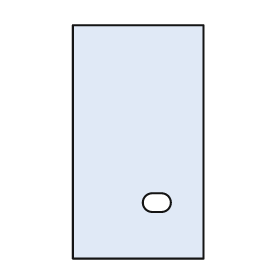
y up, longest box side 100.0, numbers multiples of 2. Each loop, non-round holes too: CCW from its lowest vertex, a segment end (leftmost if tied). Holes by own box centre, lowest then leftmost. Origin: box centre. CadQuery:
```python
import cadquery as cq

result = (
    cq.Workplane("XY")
    .moveTo(-28.0, -50.0)
    .lineTo(28.0, -50.0)
    .lineTo(28.0, 50.0)
    .lineTo(-28.0, 50.0)
    .close()
    .moveTo(6.0, -30.0)
    .lineTo(10.0, -30.0)
    .threePointArc((14.0, -26.0), (10.0, -22.0))
    .lineTo(6.0, -22.0)
    .threePointArc((2.0, -26.0), (6.0, -30.0))
    .close()
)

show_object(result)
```